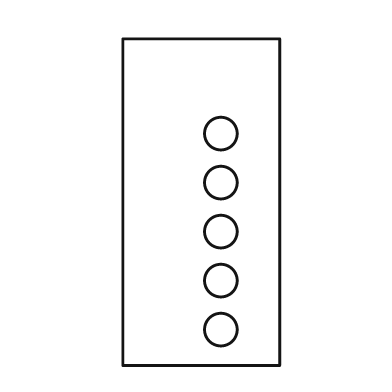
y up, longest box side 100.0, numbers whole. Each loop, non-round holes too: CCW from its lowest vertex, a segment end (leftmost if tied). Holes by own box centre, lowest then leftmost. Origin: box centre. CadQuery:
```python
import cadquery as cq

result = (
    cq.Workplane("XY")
    .moveTo(-24.0, -50.0)
    .lineTo(24.0, -50.0)
    .lineTo(24.0, 50.0)
    .lineTo(-24.0, 50.0)
    .close()
    .moveTo(6.0, -39.0)
    .circle(5.0)
    .moveTo(6.0, -24.0)
    .circle(5.0)
    .moveTo(6.0, -9.0)
    .circle(5.0)
    .moveTo(6.0, 6.0)
    .circle(5.0)
    .moveTo(6.0, 21.0)
    .circle(5.0)
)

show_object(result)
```